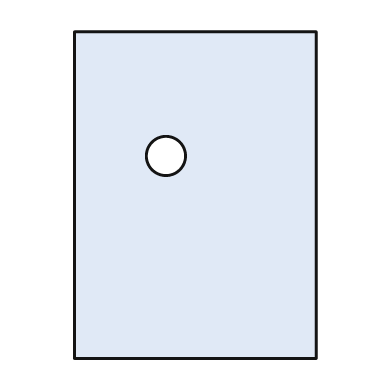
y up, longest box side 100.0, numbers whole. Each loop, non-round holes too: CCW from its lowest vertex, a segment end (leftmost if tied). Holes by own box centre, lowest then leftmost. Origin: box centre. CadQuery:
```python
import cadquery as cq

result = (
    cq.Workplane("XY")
    .moveTo(-37.0, -50.0)
    .lineTo(37.0, -50.0)
    .lineTo(37.0, 50.0)
    .lineTo(-37.0, 50.0)
    .close()
    .moveTo(-9.0, 12.0)
    .circle(6.0)
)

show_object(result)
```